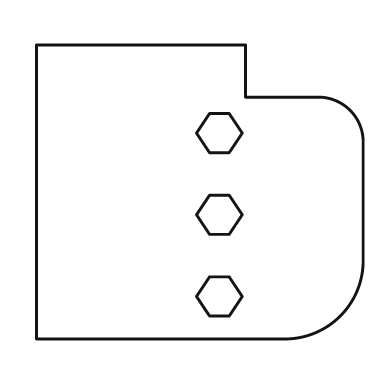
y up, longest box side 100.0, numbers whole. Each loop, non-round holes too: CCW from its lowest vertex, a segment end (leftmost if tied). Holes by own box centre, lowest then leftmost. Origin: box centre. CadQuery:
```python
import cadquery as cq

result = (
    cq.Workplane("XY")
    .moveTo(-50.0, -45.0)
    .lineTo(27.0, -45.0)
    .threePointArc((43.0, -38.0), (50.0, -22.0))
    .lineTo(50.0, 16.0)
    .threePointArc((46.0, 25.0), (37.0, 29.0))
    .lineTo(14.0, 29.0)
    .lineTo(14.0, 45.0)
    .lineTo(-50.0, 45.0)
    .close()
    .moveTo(3.0, -38.0)
    .lineTo(9.0, -38.0)
    .lineTo(13.0, -32.0)
    .lineTo(9.0, -26.0)
    .lineTo(3.0, -26.0)
    .lineTo(-1.0, -32.0)
    .close()
    .moveTo(3.0, -13.0)
    .lineTo(9.0, -13.0)
    .lineTo(13.0, -7.0)
    .lineTo(9.0, -1.0)
    .lineTo(3.0, -1.0)
    .lineTo(-1.0, -7.0)
    .close()
    .moveTo(3.0, 12.0)
    .lineTo(9.0, 12.0)
    .lineTo(13.0, 18.0)
    .lineTo(9.0, 24.0)
    .lineTo(3.0, 24.0)
    .lineTo(-1.0, 18.0)
    .close()
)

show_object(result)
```